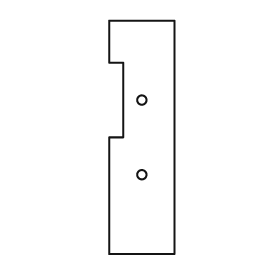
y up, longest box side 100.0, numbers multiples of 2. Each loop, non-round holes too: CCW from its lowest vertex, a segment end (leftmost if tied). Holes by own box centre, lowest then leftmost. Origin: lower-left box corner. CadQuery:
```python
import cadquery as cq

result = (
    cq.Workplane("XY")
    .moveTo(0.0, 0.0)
    .lineTo(28.0, 0.0)
    .lineTo(28.0, 100.0)
    .lineTo(0.0, 100.0)
    .lineTo(0.0, 82.0)
    .lineTo(6.0, 82.0)
    .lineTo(6.0, 50.0)
    .lineTo(0.0, 50.0)
    .close()
    .moveTo(14.0, 34.0)
    .circle(2.0)
    .moveTo(14.0, 66.0)
    .circle(2.0)
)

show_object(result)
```